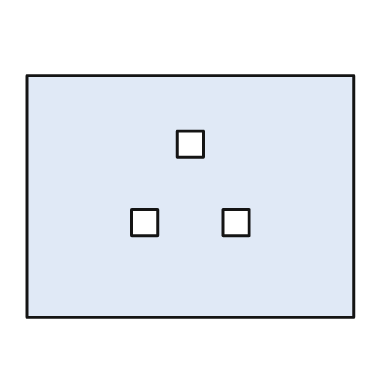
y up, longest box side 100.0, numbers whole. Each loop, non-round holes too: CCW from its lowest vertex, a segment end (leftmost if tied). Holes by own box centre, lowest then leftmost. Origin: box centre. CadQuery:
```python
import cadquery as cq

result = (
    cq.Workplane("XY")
    .moveTo(-50.0, -37.0)
    .lineTo(50.0, -37.0)
    .lineTo(50.0, 37.0)
    .lineTo(-50.0, 37.0)
    .close()
    .moveTo(-18.0, -12.0)
    .lineTo(-10.0, -12.0)
    .lineTo(-10.0, -4.0)
    .lineTo(-18.0, -4.0)
    .close()
    .moveTo(10.0, -12.0)
    .lineTo(18.0, -12.0)
    .lineTo(18.0, -4.0)
    .lineTo(10.0, -4.0)
    .close()
    .moveTo(-4.0, 12.0)
    .lineTo(4.0, 12.0)
    .lineTo(4.0, 20.0)
    .lineTo(-4.0, 20.0)
    .close()
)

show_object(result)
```